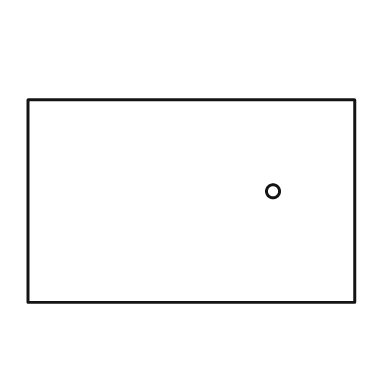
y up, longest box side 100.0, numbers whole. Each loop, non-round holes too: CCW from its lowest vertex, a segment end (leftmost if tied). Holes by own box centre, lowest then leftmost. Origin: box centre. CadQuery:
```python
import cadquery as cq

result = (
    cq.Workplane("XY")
    .moveTo(-50.0, -31.0)
    .lineTo(50.0, -31.0)
    .lineTo(50.0, 31.0)
    .lineTo(-50.0, 31.0)
    .close()
    .moveTo(25.0, 3.0)
    .circle(2.0)
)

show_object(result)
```